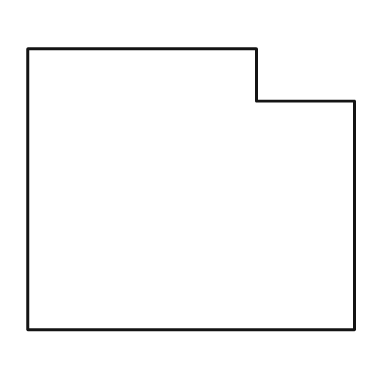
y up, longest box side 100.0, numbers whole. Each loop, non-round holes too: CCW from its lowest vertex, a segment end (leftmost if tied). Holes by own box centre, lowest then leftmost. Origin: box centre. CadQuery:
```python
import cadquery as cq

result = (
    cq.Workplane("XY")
    .moveTo(-50.0, -43.0)
    .lineTo(50.0, -43.0)
    .lineTo(50.0, 27.0)
    .lineTo(20.0, 27.0)
    .lineTo(20.0, 43.0)
    .lineTo(-50.0, 43.0)
    .close()
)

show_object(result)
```